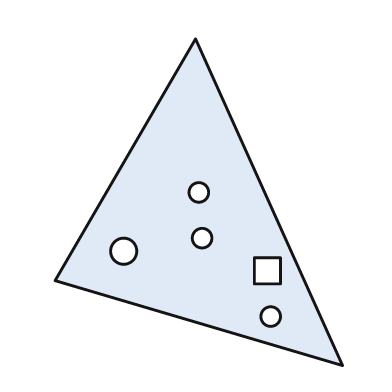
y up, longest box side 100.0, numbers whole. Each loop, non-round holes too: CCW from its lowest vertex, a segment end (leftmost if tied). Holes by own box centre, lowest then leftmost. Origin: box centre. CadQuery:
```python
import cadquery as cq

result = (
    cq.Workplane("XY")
    .moveTo(44.0, -50.0)
    .lineTo(-1.0, 50.0)
    .lineTo(-44.0, -24.0)
    .close()
    .moveTo(22.0, -35.0)
    .circle(3.0)
    .moveTo(17.0, -25.0)
    .lineTo(25.0, -25.0)
    .lineTo(25.0, -17.0)
    .lineTo(17.0, -17.0)
    .close()
    .moveTo(-23.0, -15.0)
    .circle(4.0)
    .moveTo(1.0, -11.0)
    .circle(3.0)
    .moveTo(0.0, 3.0)
    .circle(3.0)
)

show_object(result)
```